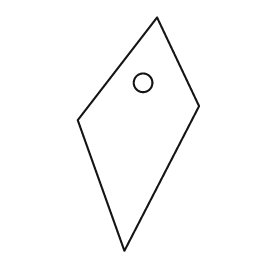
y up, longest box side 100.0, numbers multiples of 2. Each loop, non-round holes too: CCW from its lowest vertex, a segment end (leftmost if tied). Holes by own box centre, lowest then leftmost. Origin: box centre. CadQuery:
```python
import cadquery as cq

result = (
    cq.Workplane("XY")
    .moveTo(-6.0, -50.0)
    .lineTo(26.0, 12.0)
    .lineTo(8.0, 50.0)
    .lineTo(-26.0, 6.0)
    .close()
    .moveTo(2.0, 22.0)
    .circle(4.0)
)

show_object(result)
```